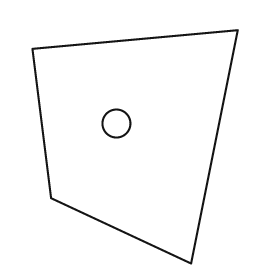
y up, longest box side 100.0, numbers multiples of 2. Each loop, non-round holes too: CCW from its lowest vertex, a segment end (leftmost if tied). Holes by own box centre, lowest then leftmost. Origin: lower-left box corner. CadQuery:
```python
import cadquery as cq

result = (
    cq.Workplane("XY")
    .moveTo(68.0, 0.0)
    .lineTo(88.0, 100.0)
    .lineTo(0.0, 92.0)
    .lineTo(8.0, 28.0)
    .close()
    .moveTo(36.0, 60.0)
    .circle(6.0)
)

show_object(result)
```